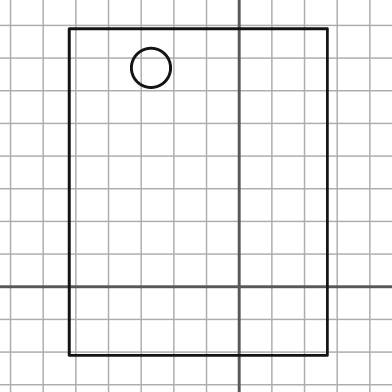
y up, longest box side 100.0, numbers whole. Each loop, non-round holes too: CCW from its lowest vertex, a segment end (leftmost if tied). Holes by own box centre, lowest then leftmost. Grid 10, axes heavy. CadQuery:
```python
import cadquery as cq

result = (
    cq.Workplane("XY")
    .moveTo(-52.0, -21.0)
    .lineTo(27.0, -21.0)
    .lineTo(27.0, 79.0)
    .lineTo(-52.0, 79.0)
    .close()
    .moveTo(-27.0, 67.0)
    .circle(6.0)
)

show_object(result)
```